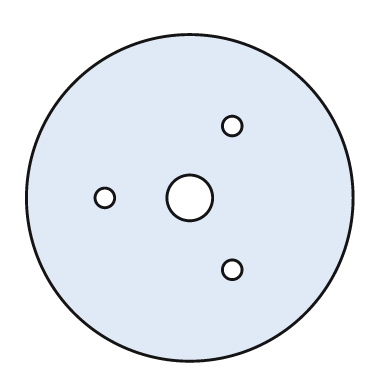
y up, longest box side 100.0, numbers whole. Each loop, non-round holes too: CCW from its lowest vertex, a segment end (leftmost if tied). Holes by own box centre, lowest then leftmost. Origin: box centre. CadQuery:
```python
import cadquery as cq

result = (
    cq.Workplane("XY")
    .moveTo(0.0, 0.0)
    .circle(50.0)
    .moveTo(13.0, -22.0)
    .circle(3.0)
    .moveTo(-26.0, 0.0)
    .circle(3.0)
    .moveTo(0.0, 0.0)
    .circle(7.0)
    .moveTo(13.0, 22.0)
    .circle(3.0)
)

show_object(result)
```